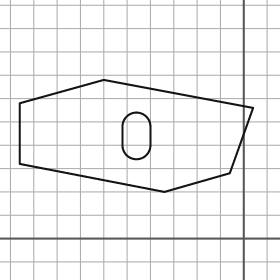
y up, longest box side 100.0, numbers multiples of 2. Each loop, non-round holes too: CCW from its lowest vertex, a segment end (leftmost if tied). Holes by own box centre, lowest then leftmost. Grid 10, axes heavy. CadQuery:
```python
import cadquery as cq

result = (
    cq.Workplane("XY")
    .moveTo(-34.0, 20.0)
    .lineTo(-6.0, 28.0)
    .lineTo(4.0, 56.0)
    .lineTo(-60.0, 68.0)
    .lineTo(-96.0, 58.0)
    .lineTo(-96.0, 32.0)
    .close()
    .moveTo(-52.0, 40.0)
    .threePointArc((-46.0, 34.0), (-40.0, 40.0))
    .lineTo(-40.0, 48.0)
    .threePointArc((-46.0, 54.0), (-52.0, 48.0))
    .close()
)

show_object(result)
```